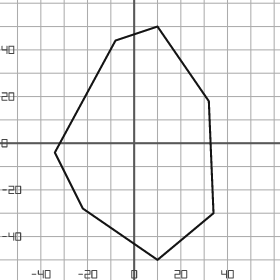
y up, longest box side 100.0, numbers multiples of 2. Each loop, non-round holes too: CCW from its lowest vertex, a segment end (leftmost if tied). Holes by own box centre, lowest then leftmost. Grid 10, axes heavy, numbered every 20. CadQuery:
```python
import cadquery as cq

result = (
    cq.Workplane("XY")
    .moveTo(10.0, -50.0)
    .lineTo(34.0, -30.0)
    .lineTo(32.0, 18.0)
    .lineTo(10.0, 50.0)
    .lineTo(-8.0, 44.0)
    .lineTo(-34.0, -4.0)
    .lineTo(-22.0, -28.0)
    .close()
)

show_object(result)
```